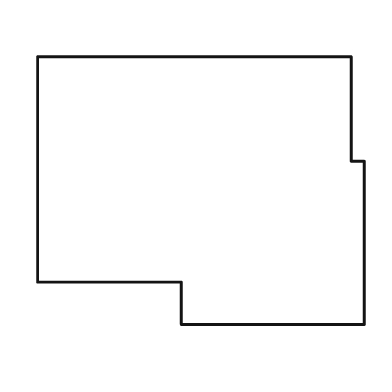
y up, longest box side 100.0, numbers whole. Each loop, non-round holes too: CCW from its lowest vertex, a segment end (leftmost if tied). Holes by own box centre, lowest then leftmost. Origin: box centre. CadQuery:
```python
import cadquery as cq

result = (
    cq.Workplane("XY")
    .moveTo(-6.0, -41.0)
    .lineTo(50.0, -41.0)
    .lineTo(50.0, 9.0)
    .lineTo(46.0, 9.0)
    .lineTo(46.0, 41.0)
    .lineTo(-50.0, 41.0)
    .lineTo(-50.0, -28.0)
    .lineTo(-6.0, -28.0)
    .close()
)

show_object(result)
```